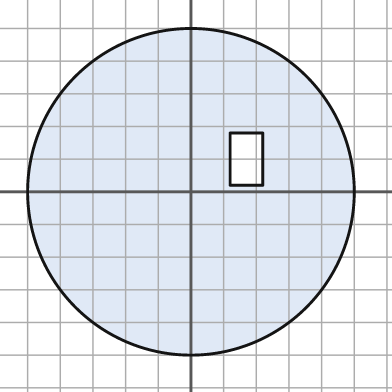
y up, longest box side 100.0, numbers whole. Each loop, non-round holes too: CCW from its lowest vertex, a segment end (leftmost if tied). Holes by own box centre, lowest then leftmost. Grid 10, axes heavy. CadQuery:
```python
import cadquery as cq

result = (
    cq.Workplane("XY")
    .moveTo(0.0, 0.0)
    .circle(50.0)
    .moveTo(12.0, 2.0)
    .lineTo(22.0, 2.0)
    .lineTo(22.0, 18.0)
    .lineTo(12.0, 18.0)
    .close()
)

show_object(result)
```